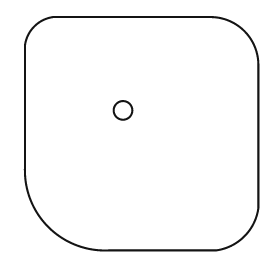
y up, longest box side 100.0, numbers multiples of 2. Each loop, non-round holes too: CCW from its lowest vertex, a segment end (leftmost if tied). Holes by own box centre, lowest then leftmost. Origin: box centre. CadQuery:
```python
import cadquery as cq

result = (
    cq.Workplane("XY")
    .moveTo(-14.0, -50.0)
    .lineTo(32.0, -50.0)
    .threePointArc((44.0, -44.0), (50.0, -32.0))
    .lineTo(50.0, 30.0)
    .threePointArc((44.0, 44.0), (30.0, 50.0))
    .lineTo(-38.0, 50.0)
    .threePointArc((-46.0, 46.0), (-50.0, 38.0))
    .lineTo(-50.0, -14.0)
    .threePointArc((-40.0, -40.0), (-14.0, -50.0))
    .close()
    .moveTo(-8.0, 10.0)
    .circle(4.0)
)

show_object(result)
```